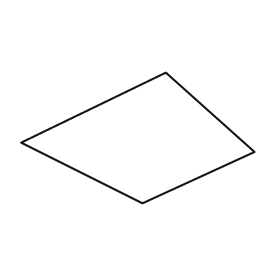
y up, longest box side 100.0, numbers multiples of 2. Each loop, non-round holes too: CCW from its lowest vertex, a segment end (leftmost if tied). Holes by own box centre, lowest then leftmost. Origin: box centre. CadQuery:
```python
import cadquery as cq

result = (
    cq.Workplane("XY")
    .moveTo(2.0, -28.0)
    .lineTo(50.0, -6.0)
    .lineTo(12.0, 28.0)
    .lineTo(-50.0, -2.0)
    .close()
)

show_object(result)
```